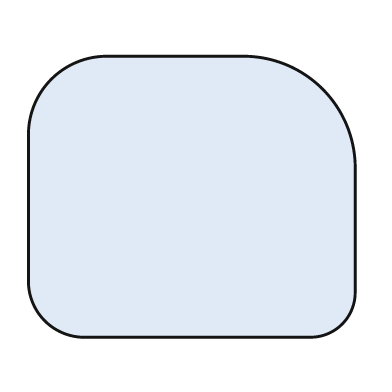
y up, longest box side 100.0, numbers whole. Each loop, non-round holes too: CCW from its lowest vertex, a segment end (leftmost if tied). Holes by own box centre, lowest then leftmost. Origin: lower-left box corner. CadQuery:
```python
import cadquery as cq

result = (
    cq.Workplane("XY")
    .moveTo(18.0, 0.0)
    .lineTo(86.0, 0.0)
    .threePointArc((96.0, 4.0), (100.0, 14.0))
    .lineTo(100.0, 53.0)
    .threePointArc((90.0, 76.0), (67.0, 86.0))
    .lineTo(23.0, 86.0)
    .threePointArc((7.0, 79.0), (0.0, 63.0))
    .lineTo(0.0, 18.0)
    .threePointArc((5.0, 5.0), (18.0, 0.0))
    .close()
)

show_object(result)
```